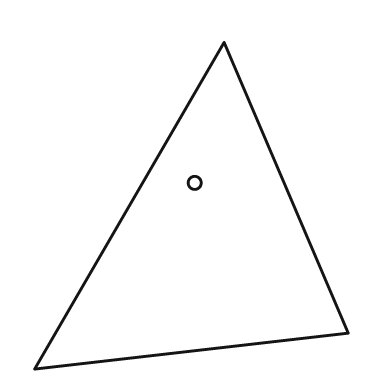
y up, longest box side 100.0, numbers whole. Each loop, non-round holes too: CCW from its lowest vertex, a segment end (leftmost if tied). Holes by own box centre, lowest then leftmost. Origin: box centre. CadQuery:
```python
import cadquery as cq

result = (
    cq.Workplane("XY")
    .moveTo(-48.0, -50.0)
    .lineTo(48.0, -39.0)
    .lineTo(10.0, 50.0)
    .close()
    .moveTo(1.0, 7.0)
    .circle(2.0)
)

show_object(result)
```